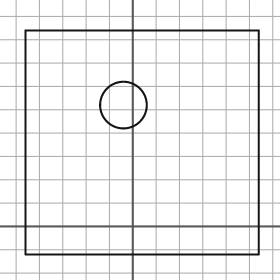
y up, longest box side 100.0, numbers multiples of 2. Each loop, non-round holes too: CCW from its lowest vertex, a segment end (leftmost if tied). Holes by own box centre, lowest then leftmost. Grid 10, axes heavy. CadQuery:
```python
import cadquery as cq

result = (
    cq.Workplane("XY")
    .moveTo(-46.0, -12.0)
    .lineTo(54.0, -12.0)
    .lineTo(54.0, 84.0)
    .lineTo(-46.0, 84.0)
    .close()
    .moveTo(-4.0, 52.0)
    .circle(10.0)
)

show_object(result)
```